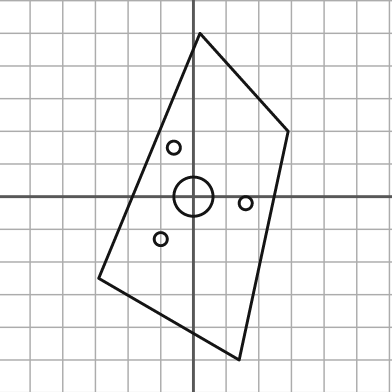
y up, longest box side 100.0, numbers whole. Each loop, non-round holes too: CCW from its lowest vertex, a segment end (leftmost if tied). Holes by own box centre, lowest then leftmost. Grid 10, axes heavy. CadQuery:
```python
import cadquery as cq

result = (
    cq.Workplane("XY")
    .moveTo(14.0, -50.0)
    .lineTo(29.0, 20.0)
    .lineTo(2.0, 50.0)
    .lineTo(-29.0, -25.0)
    .close()
    .moveTo(-10.0, -13.0)
    .circle(2.0)
    .moveTo(16.0, -2.0)
    .circle(2.0)
    .moveTo(0.0, 0.0)
    .circle(6.0)
    .moveTo(-6.0, 15.0)
    .circle(2.0)
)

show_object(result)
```